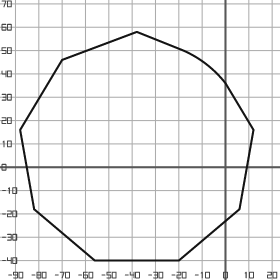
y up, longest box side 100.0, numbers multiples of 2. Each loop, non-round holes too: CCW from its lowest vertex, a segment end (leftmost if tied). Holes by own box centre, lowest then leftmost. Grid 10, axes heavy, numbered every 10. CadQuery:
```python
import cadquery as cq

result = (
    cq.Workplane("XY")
    .moveTo(-56.0, -40.0)
    .lineTo(-20.0, -40.0)
    .lineTo(6.0, -18.0)
    .lineTo(12.0, 16.0)
    .lineTo(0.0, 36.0)
    .threePointArc((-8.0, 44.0), (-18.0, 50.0))
    .lineTo(-38.0, 58.0)
    .lineTo(-70.0, 46.0)
    .lineTo(-88.0, 16.0)
    .lineTo(-82.0, -18.0)
    .close()
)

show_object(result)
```